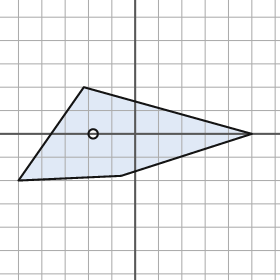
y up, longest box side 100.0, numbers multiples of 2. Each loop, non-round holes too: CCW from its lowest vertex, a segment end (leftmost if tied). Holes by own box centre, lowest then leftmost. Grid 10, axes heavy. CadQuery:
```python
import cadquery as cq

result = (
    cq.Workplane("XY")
    .moveTo(-50.0, -20.0)
    .lineTo(-6.0, -18.0)
    .lineTo(50.0, 0.0)
    .lineTo(-22.0, 20.0)
    .close()
    .moveTo(-18.0, 0.0)
    .circle(2.0)
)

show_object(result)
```